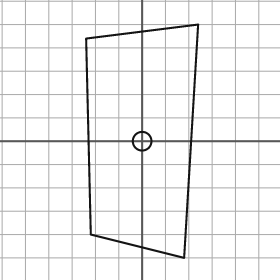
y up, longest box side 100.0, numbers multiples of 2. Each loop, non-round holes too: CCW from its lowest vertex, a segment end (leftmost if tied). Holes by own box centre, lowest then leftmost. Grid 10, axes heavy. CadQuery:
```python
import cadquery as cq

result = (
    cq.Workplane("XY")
    .moveTo(18.0, -50.0)
    .lineTo(24.0, 50.0)
    .lineTo(-24.0, 44.0)
    .lineTo(-22.0, -40.0)
    .close()
    .moveTo(0.0, 0.0)
    .circle(4.0)
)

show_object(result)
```